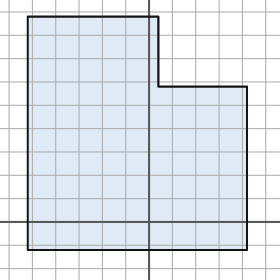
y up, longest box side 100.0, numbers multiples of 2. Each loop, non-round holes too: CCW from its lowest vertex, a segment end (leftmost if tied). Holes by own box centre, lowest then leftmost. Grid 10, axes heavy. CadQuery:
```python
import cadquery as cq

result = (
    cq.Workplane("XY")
    .moveTo(-52.0, -12.0)
    .lineTo(42.0, -12.0)
    .lineTo(42.0, 58.0)
    .lineTo(4.0, 58.0)
    .lineTo(4.0, 88.0)
    .lineTo(-52.0, 88.0)
    .close()
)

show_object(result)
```